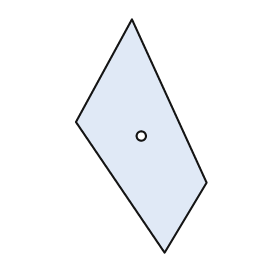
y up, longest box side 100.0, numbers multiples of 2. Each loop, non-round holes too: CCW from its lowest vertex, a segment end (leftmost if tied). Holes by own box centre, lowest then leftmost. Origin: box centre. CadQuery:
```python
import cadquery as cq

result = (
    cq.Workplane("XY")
    .moveTo(10.0, -50.0)
    .lineTo(28.0, -20.0)
    .lineTo(-4.0, 50.0)
    .lineTo(-28.0, 6.0)
    .close()
    .moveTo(0.0, 0.0)
    .circle(2.0)
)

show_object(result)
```